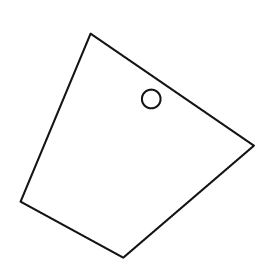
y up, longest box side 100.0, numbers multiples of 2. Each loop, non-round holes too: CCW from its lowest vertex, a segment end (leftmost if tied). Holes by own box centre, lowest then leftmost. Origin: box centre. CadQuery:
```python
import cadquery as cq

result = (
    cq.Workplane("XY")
    .moveTo(-6.0, -48.0)
    .lineTo(50.0, 0.0)
    .lineTo(-20.0, 48.0)
    .lineTo(-50.0, -24.0)
    .close()
    .moveTo(6.0, 20.0)
    .circle(4.0)
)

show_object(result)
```